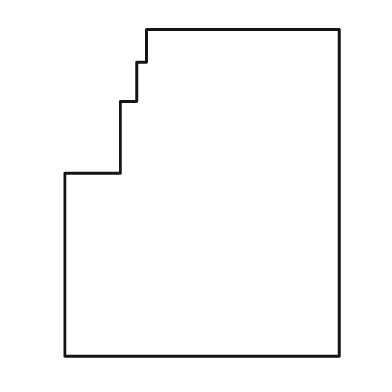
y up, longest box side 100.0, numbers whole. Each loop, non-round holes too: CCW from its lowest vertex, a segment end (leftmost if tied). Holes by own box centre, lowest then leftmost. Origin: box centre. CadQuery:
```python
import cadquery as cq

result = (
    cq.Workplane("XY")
    .moveTo(-42.0, -50.0)
    .lineTo(42.0, -50.0)
    .lineTo(42.0, 50.0)
    .lineTo(-17.0, 50.0)
    .lineTo(-17.0, 40.0)
    .lineTo(-20.0, 40.0)
    .lineTo(-20.0, 28.0)
    .lineTo(-25.0, 28.0)
    .lineTo(-25.0, 6.0)
    .lineTo(-42.0, 6.0)
    .close()
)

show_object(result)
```